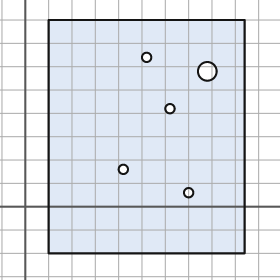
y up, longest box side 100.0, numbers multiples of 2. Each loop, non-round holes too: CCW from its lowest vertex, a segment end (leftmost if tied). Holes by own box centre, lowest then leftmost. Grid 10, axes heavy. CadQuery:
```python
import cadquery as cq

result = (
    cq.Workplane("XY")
    .moveTo(10.0, -20.0)
    .lineTo(94.0, -20.0)
    .lineTo(94.0, 80.0)
    .lineTo(10.0, 80.0)
    .close()
    .moveTo(70.0, 6.0)
    .circle(2.0)
    .moveTo(42.0, 16.0)
    .circle(2.0)
    .moveTo(62.0, 42.0)
    .circle(2.0)
    .moveTo(78.0, 58.0)
    .circle(4.0)
    .moveTo(52.0, 64.0)
    .circle(2.0)
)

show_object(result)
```